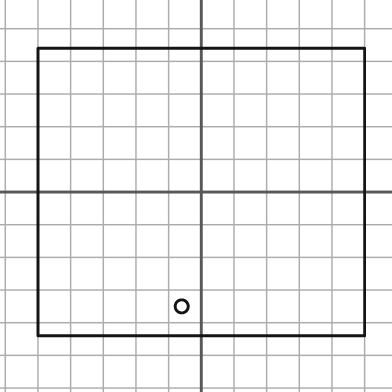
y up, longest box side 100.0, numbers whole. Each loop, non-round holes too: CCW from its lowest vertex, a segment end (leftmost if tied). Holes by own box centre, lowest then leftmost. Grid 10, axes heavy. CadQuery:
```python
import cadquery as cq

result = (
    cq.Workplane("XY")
    .moveTo(-50.0, -44.0)
    .lineTo(50.0, -44.0)
    .lineTo(50.0, 44.0)
    .lineTo(-50.0, 44.0)
    .close()
    .moveTo(-6.0, -35.0)
    .circle(2.0)
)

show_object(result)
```